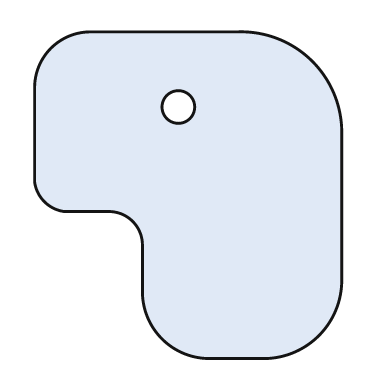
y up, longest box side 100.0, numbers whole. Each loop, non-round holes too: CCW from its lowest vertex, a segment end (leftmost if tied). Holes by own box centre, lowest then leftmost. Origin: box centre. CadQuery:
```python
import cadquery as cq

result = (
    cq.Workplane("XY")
    .moveTo(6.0, -50.0)
    .lineTo(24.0, -50.0)
    .threePointArc((40.0, -43.0), (47.0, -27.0))
    .lineTo(47.0, 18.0)
    .threePointArc((38.0, 41.0), (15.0, 50.0))
    .lineTo(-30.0, 50.0)
    .threePointArc((-42.0, 45.0), (-47.0, 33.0))
    .lineTo(-47.0, 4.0)
    .threePointArc((-44.0, -2.0), (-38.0, -5.0))
    .lineTo(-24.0, -5.0)
    .threePointArc((-17.0, -8.0), (-14.0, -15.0))
    .lineTo(-14.0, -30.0)
    .threePointArc((-8.0, -44.0), (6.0, -50.0))
    .close()
    .moveTo(-3.0, 27.0)
    .circle(5.0)
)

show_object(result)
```